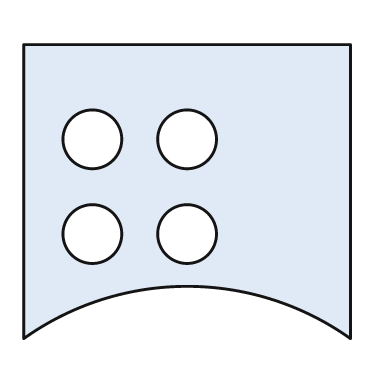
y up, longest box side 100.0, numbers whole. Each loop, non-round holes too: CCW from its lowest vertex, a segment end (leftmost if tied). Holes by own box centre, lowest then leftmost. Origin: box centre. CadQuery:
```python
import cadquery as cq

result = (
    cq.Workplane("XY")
    .moveTo(-50.0, -45.0)
    .threePointArc((0.0, -29.0), (50.0, -45.0))
    .lineTo(50.0, 45.0)
    .lineTo(-50.0, 45.0)
    .close()
    .moveTo(-29.0, -13.0)
    .circle(9.0)
    .moveTo(0.0, -13.0)
    .circle(9.0)
    .moveTo(-29.0, 16.0)
    .circle(9.0)
    .moveTo(0.0, 16.0)
    .circle(9.0)
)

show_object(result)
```